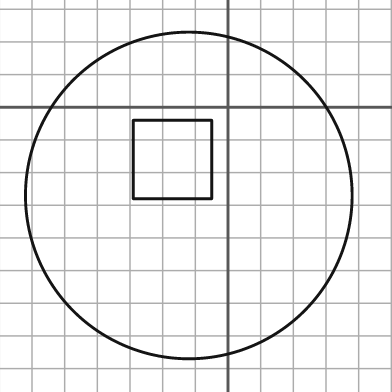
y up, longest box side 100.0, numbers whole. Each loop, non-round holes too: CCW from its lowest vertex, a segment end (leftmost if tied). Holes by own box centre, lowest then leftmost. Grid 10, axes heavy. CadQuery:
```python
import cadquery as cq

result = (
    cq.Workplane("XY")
    .moveTo(-12.0, -27.0)
    .circle(50.0)
    .moveTo(-29.0, -28.0)
    .lineTo(-5.0, -28.0)
    .lineTo(-5.0, -4.0)
    .lineTo(-29.0, -4.0)
    .close()
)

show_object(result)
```